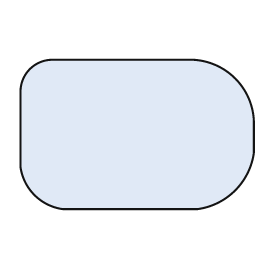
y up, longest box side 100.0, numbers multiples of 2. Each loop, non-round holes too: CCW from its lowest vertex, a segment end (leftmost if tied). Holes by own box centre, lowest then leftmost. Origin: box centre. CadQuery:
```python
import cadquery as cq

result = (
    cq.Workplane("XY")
    .moveTo(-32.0, -32.0)
    .lineTo(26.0, -32.0)
    .threePointArc((42.0, -24.0), (50.0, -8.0))
    .lineTo(50.0, 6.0)
    .threePointArc((42.0, 24.0), (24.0, 32.0))
    .lineTo(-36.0, 32.0)
    .threePointArc((-46.0, 28.0), (-50.0, 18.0))
    .lineTo(-50.0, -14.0)
    .threePointArc((-44.0, -26.0), (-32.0, -32.0))
    .close()
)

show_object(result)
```